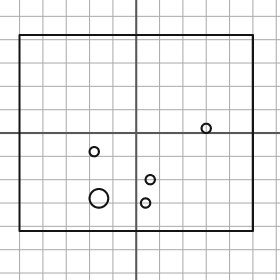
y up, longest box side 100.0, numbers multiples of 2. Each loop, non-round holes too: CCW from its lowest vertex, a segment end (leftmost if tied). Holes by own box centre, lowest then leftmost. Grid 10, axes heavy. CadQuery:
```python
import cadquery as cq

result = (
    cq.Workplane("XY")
    .moveTo(-50.0, -42.0)
    .lineTo(50.0, -42.0)
    .lineTo(50.0, 42.0)
    .lineTo(-50.0, 42.0)
    .close()
    .moveTo(4.0, -30.0)
    .circle(2.0)
    .moveTo(-16.0, -28.0)
    .circle(4.0)
    .moveTo(6.0, -20.0)
    .circle(2.0)
    .moveTo(-18.0, -8.0)
    .circle(2.0)
    .moveTo(30.0, 2.0)
    .circle(2.0)
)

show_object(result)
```